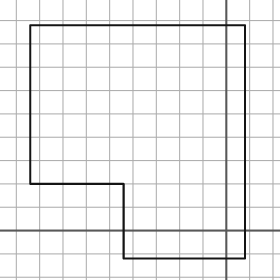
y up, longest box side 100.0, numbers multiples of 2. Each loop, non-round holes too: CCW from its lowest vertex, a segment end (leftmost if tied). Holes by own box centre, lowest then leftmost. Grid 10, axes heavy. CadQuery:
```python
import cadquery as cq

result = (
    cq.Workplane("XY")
    .moveTo(-44.0, -12.0)
    .lineTo(8.0, -12.0)
    .lineTo(8.0, 88.0)
    .lineTo(-84.0, 88.0)
    .lineTo(-84.0, 20.0)
    .lineTo(-44.0, 20.0)
    .close()
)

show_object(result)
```